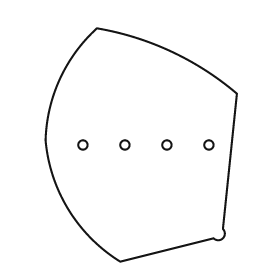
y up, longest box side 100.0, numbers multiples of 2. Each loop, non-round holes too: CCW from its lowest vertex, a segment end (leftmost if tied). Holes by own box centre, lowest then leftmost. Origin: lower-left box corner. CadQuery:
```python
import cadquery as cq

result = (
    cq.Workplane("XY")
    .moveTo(32.0, 0.0)
    .lineTo(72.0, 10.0)
    .threePointArc((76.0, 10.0), (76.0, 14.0))
    .lineTo(82.0, 72.0)
    .threePointArc((54.0, 90.0), (22.0, 100.0))
    .threePointArc((6.0, 78.0), (0.0, 52.0))
    .threePointArc((10.0, 22.0), (32.0, 0.0))
    .close()
    .moveTo(16.0, 50.0)
    .circle(2.0)
    .moveTo(34.0, 50.0)
    .circle(2.0)
    .moveTo(52.0, 50.0)
    .circle(2.0)
    .moveTo(70.0, 50.0)
    .circle(2.0)
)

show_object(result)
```